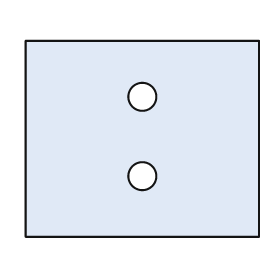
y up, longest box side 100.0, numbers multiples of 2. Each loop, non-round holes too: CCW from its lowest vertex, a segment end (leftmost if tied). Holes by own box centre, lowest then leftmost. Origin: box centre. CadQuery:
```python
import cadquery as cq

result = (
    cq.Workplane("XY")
    .moveTo(-50.0, -42.0)
    .lineTo(50.0, -42.0)
    .lineTo(50.0, 42.0)
    .lineTo(-50.0, 42.0)
    .close()
    .moveTo(0.0, -16.0)
    .circle(6.0)
    .moveTo(0.0, 18.0)
    .circle(6.0)
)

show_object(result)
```